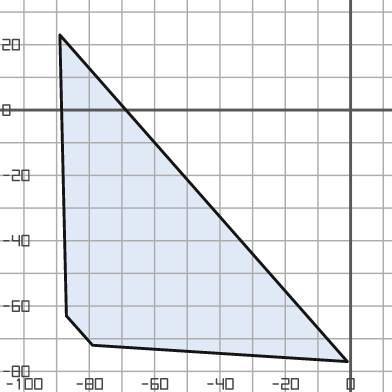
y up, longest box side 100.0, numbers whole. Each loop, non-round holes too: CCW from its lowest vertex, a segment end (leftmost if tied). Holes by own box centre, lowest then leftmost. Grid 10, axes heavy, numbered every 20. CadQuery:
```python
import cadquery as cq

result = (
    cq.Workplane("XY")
    .moveTo(-1.0, -77.0)
    .lineTo(-89.0, 23.0)
    .lineTo(-87.0, -63.0)
    .lineTo(-79.0, -72.0)
    .close()
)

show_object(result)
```